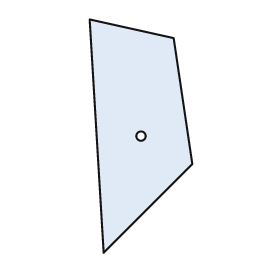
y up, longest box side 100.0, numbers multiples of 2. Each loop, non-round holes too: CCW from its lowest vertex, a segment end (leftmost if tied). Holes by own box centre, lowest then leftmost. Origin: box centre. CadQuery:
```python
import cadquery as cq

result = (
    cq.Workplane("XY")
    .moveTo(-16.0, -50.0)
    .lineTo(22.0, -12.0)
    .lineTo(14.0, 42.0)
    .lineTo(-22.0, 50.0)
    .close()
    .moveTo(0.0, 0.0)
    .circle(2.0)
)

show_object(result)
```